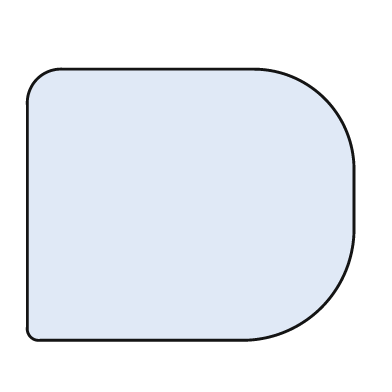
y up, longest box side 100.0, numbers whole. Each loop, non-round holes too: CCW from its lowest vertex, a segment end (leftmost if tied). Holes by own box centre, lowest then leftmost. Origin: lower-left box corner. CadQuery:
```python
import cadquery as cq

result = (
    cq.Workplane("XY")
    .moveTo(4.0, 0.0)
    .lineTo(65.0, 0.0)
    .threePointArc((90.0, 10.0), (100.0, 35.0))
    .lineTo(100.0, 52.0)
    .threePointArc((91.0, 74.0), (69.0, 83.0))
    .lineTo(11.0, 83.0)
    .threePointArc((3.0, 80.0), (0.0, 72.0))
    .lineTo(0.0, 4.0)
    .threePointArc((1.0, 1.0), (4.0, 0.0))
    .close()
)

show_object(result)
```